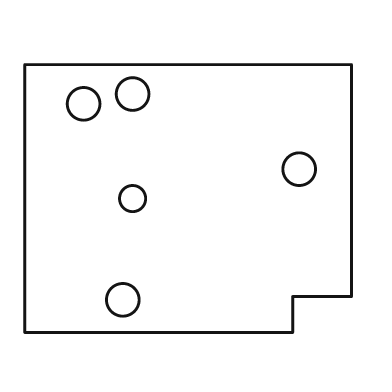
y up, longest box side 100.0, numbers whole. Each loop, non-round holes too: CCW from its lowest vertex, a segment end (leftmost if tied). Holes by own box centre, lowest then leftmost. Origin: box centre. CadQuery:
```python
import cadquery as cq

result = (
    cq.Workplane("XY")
    .moveTo(-50.0, -41.0)
    .lineTo(32.0, -41.0)
    .lineTo(32.0, -30.0)
    .lineTo(50.0, -30.0)
    .lineTo(50.0, 41.0)
    .lineTo(-50.0, 41.0)
    .close()
    .moveTo(-20.0, -31.0)
    .circle(5.0)
    .moveTo(-17.0, 0.0)
    .circle(4.0)
    .moveTo(34.0, 9.0)
    .circle(5.0)
    .moveTo(-32.0, 29.0)
    .circle(5.0)
    .moveTo(-17.0, 32.0)
    .circle(5.0)
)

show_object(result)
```